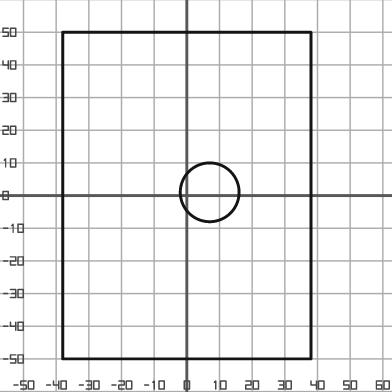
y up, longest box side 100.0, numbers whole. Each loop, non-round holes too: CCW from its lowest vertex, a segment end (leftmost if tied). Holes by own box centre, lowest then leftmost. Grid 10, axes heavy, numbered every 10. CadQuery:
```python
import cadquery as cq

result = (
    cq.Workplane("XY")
    .moveTo(-38.0, -50.0)
    .lineTo(38.0, -50.0)
    .lineTo(38.0, 50.0)
    .lineTo(-38.0, 50.0)
    .close()
    .moveTo(7.0, 1.0)
    .circle(9.0)
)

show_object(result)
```